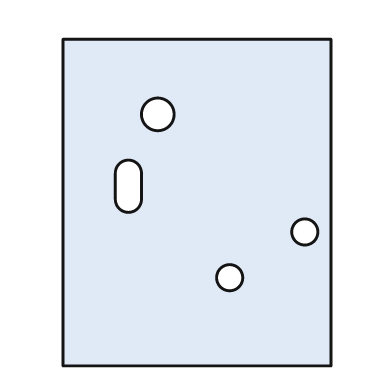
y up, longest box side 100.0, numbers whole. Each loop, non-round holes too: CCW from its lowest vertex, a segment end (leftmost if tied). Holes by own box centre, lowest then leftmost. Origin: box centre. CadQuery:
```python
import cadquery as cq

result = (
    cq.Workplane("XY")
    .moveTo(-41.0, -50.0)
    .lineTo(41.0, -50.0)
    .lineTo(41.0, 50.0)
    .lineTo(-41.0, 50.0)
    .close()
    .moveTo(10.0, -23.0)
    .circle(4.0)
    .moveTo(33.0, -9.0)
    .circle(4.0)
    .moveTo(-25.0, 1.0)
    .threePointArc((-21.0, -3.0), (-17.0, 1.0))
    .lineTo(-17.0, 9.0)
    .threePointArc((-21.0, 13.0), (-25.0, 9.0))
    .close()
    .moveTo(-12.0, 27.0)
    .circle(5.0)
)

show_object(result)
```